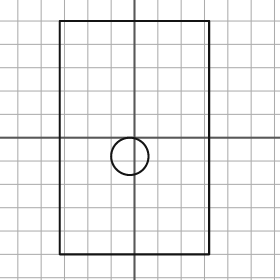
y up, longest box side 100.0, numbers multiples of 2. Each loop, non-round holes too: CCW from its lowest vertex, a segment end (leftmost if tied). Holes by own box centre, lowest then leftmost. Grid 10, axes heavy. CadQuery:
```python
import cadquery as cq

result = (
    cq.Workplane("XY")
    .moveTo(-32.0, -50.0)
    .lineTo(32.0, -50.0)
    .lineTo(32.0, 50.0)
    .lineTo(-32.0, 50.0)
    .close()
    .moveTo(-2.0, -8.0)
    .circle(8.0)
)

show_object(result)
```